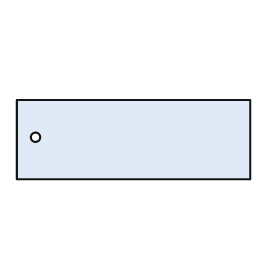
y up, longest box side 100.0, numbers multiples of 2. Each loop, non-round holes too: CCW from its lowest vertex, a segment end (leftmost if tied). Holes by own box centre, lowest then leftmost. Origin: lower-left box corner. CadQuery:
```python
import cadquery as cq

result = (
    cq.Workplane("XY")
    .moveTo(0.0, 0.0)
    .lineTo(100.0, 0.0)
    .lineTo(100.0, 34.0)
    .lineTo(0.0, 34.0)
    .close()
    .moveTo(8.0, 18.0)
    .circle(2.0)
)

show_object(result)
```